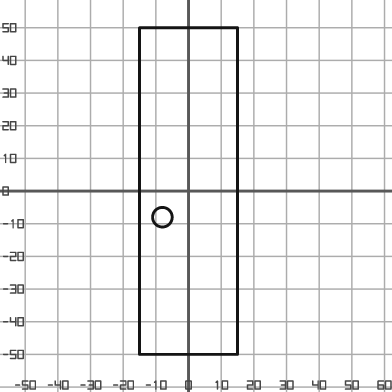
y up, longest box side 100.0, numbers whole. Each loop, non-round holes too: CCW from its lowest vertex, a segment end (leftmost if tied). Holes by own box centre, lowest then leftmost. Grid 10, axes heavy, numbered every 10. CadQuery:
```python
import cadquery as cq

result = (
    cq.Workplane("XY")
    .moveTo(-15.0, -50.0)
    .lineTo(15.0, -50.0)
    .lineTo(15.0, 50.0)
    .lineTo(-15.0, 50.0)
    .close()
    .moveTo(-8.0, -8.0)
    .circle(3.0)
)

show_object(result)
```